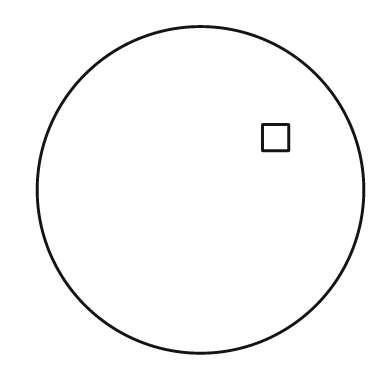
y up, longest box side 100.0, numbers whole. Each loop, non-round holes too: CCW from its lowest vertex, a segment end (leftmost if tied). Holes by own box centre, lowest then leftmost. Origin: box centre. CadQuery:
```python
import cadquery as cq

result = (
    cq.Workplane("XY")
    .moveTo(0.0, 0.0)
    .circle(50.0)
    .moveTo(19.0, 12.0)
    .lineTo(27.0, 12.0)
    .lineTo(27.0, 20.0)
    .lineTo(19.0, 20.0)
    .close()
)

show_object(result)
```